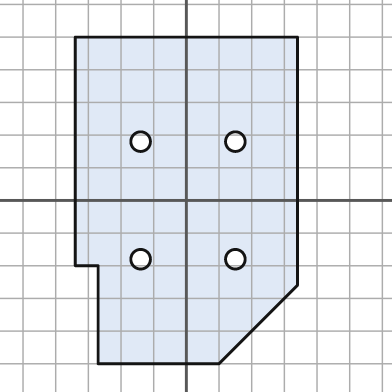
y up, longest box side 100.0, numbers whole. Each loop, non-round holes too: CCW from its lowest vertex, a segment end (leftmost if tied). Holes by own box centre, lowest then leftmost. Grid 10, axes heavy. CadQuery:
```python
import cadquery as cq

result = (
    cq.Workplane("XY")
    .moveTo(-27.0, -50.0)
    .lineTo(10.0, -50.0)
    .lineTo(34.0, -26.0)
    .lineTo(34.0, 50.0)
    .lineTo(-34.0, 50.0)
    .lineTo(-34.0, -20.0)
    .lineTo(-27.0, -20.0)
    .close()
    .moveTo(-14.0, -18.0)
    .circle(3.0)
    .moveTo(15.0, -18.0)
    .circle(3.0)
    .moveTo(-14.0, 18.0)
    .circle(3.0)
    .moveTo(15.0, 18.0)
    .circle(3.0)
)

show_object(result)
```